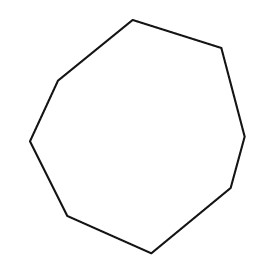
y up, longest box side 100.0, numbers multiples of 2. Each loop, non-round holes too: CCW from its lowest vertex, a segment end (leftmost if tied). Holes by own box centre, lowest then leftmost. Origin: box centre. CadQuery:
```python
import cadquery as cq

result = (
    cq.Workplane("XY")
    .moveTo(6.0, -50.0)
    .lineTo(40.0, -22.0)
    .lineTo(46.0, 0.0)
    .lineTo(36.0, 38.0)
    .lineTo(-2.0, 50.0)
    .lineTo(-34.0, 24.0)
    .lineTo(-46.0, -2.0)
    .lineTo(-30.0, -34.0)
    .close()
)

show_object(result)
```